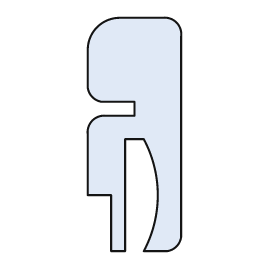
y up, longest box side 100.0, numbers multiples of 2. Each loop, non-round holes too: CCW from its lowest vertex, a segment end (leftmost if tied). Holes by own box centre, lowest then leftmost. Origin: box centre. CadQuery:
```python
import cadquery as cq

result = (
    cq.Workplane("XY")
    .moveTo(-10.0, -50.0)
    .lineTo(-4.0, -50.0)
    .lineTo(-4.0, -2.0)
    .lineTo(4.0, -2.0)
    .threePointArc((10.0, -26.0), (4.0, -50.0))
    .lineTo(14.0, -50.0)
    .threePointArc((18.0, -48.0), (20.0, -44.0))
    .lineTo(20.0, 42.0)
    .threePointArc((18.0, 48.0), (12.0, 50.0))
    .lineTo(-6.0, 50.0)
    .threePointArc((-16.0, 46.0), (-20.0, 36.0))
    .lineTo(-20.0, 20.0)
    .threePointArc((-18.0, 16.0), (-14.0, 14.0))
    .lineTo(0.0, 14.0)
    .lineTo(0.0, 8.0)
    .lineTo(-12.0, 8.0)
    .threePointArc((-18.0, 6.0), (-20.0, 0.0))
    .lineTo(-20.0, -26.0)
    .lineTo(-10.0, -26.0)
    .close()
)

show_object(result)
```